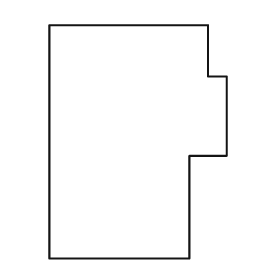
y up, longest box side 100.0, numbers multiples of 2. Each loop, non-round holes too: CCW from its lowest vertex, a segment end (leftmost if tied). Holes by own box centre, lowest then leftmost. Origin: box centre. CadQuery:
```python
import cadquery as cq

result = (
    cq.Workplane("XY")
    .moveTo(-38.0, -50.0)
    .lineTo(22.0, -50.0)
    .lineTo(22.0, -6.0)
    .lineTo(38.0, -6.0)
    .lineTo(38.0, 28.0)
    .lineTo(30.0, 28.0)
    .lineTo(30.0, 50.0)
    .lineTo(-38.0, 50.0)
    .close()
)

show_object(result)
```